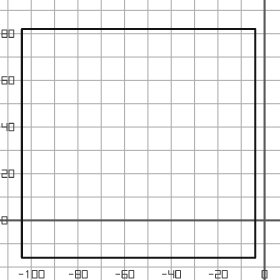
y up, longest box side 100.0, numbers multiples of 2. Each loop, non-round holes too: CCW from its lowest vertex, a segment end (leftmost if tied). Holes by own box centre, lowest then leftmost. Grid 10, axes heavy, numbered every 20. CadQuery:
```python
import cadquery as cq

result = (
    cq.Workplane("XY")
    .moveTo(-104.0, -16.0)
    .lineTo(-4.0, -16.0)
    .lineTo(-4.0, 82.0)
    .lineTo(-104.0, 82.0)
    .close()
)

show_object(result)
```